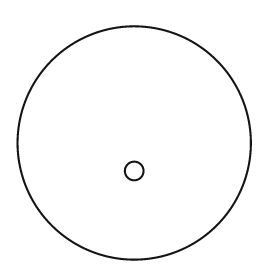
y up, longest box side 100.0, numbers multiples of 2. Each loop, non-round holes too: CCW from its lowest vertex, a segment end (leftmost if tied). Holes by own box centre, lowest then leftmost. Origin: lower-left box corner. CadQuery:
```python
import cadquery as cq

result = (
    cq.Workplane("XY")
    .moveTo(50.0, 50.0)
    .circle(50.0)
    .moveTo(50.0, 38.0)
    .circle(4.0)
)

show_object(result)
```